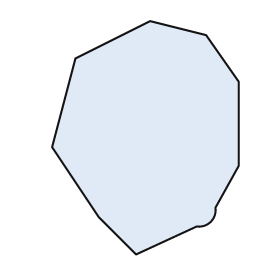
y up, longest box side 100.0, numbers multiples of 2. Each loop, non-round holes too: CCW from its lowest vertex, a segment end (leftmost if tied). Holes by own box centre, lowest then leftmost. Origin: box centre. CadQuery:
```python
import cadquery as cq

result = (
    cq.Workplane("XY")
    .moveTo(-4.0, -50.0)
    .lineTo(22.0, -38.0)
    .threePointArc((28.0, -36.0), (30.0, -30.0))
    .lineTo(40.0, -12.0)
    .lineTo(40.0, 24.0)
    .lineTo(26.0, 44.0)
    .lineTo(2.0, 50.0)
    .lineTo(-30.0, 34.0)
    .lineTo(-40.0, -4.0)
    .lineTo(-20.0, -34.0)
    .close()
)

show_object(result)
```